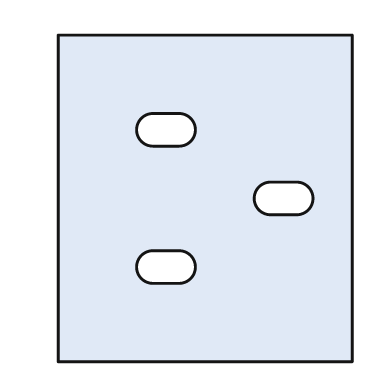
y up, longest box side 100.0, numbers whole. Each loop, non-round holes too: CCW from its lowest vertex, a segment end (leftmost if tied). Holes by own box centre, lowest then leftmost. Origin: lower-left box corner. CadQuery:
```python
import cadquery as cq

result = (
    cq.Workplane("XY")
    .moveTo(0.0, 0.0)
    .lineTo(90.0, 0.0)
    .lineTo(90.0, 100.0)
    .lineTo(0.0, 100.0)
    .close()
    .moveTo(29.0, 24.0)
    .lineTo(37.0, 24.0)
    .threePointArc((42.0, 29.0), (37.0, 34.0))
    .lineTo(29.0, 34.0)
    .threePointArc((24.0, 29.0), (29.0, 24.0))
    .close()
    .moveTo(65.0, 45.0)
    .lineTo(73.0, 45.0)
    .threePointArc((78.0, 50.0), (73.0, 55.0))
    .lineTo(65.0, 55.0)
    .threePointArc((60.0, 50.0), (65.0, 45.0))
    .close()
    .moveTo(29.0, 66.0)
    .lineTo(37.0, 66.0)
    .threePointArc((42.0, 71.0), (37.0, 76.0))
    .lineTo(29.0, 76.0)
    .threePointArc((24.0, 71.0), (29.0, 66.0))
    .close()
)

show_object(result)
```